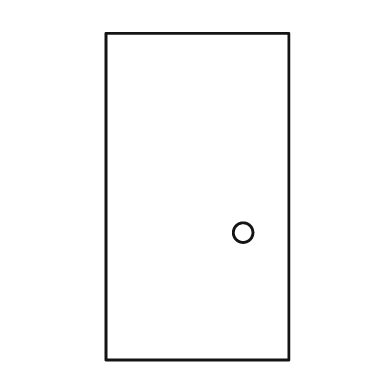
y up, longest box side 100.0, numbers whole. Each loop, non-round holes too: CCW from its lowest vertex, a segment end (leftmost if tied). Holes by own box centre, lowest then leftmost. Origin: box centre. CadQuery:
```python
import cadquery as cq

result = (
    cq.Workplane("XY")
    .moveTo(-28.0, -50.0)
    .lineTo(28.0, -50.0)
    .lineTo(28.0, 50.0)
    .lineTo(-28.0, 50.0)
    .close()
    .moveTo(14.0, -11.0)
    .circle(3.0)
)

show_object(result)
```